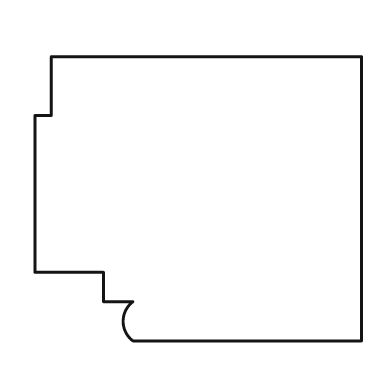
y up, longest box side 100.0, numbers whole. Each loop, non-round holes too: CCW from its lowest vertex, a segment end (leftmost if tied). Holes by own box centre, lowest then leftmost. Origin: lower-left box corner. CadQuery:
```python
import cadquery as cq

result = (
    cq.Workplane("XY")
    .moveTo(30.0, 0.0)
    .lineTo(100.0, 0.0)
    .lineTo(100.0, 87.0)
    .lineTo(5.0, 87.0)
    .lineTo(5.0, 69.0)
    .lineTo(0.0, 69.0)
    .lineTo(0.0, 21.0)
    .lineTo(21.0, 21.0)
    .lineTo(21.0, 12.0)
    .lineTo(30.0, 12.0)
    .threePointArc((27.0, 6.0), (30.0, 0.0))
    .close()
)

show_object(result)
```